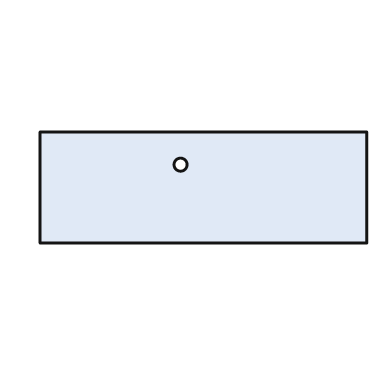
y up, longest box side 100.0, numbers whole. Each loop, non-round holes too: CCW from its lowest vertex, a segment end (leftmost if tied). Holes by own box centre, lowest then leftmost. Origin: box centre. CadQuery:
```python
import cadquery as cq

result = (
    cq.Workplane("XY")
    .moveTo(-50.0, -17.0)
    .lineTo(50.0, -17.0)
    .lineTo(50.0, 17.0)
    .lineTo(-50.0, 17.0)
    .close()
    .moveTo(-7.0, 7.0)
    .circle(2.0)
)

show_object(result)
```